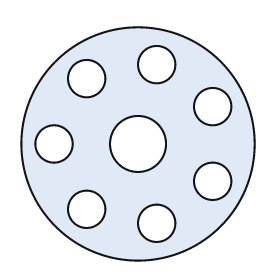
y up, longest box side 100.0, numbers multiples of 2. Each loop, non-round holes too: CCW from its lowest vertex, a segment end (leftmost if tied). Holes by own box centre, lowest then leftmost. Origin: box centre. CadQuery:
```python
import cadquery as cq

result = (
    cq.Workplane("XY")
    .moveTo(0.0, 0.0)
    .circle(50.0)
    .moveTo(8.0, -34.0)
    .circle(8.0)
    .moveTo(-22.0, -28.0)
    .circle(8.0)
    .moveTo(32.0, -16.0)
    .circle(8.0)
    .moveTo(-36.0, 0.0)
    .circle(8.0)
    .moveTo(0.0, 0.0)
    .circle(12.0)
    .moveTo(32.0, 16.0)
    .circle(8.0)
    .moveTo(-22.0, 28.0)
    .circle(8.0)
    .moveTo(8.0, 34.0)
    .circle(8.0)
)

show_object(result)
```